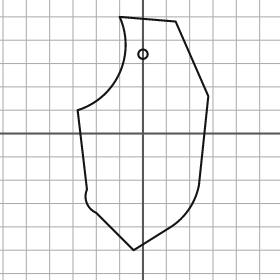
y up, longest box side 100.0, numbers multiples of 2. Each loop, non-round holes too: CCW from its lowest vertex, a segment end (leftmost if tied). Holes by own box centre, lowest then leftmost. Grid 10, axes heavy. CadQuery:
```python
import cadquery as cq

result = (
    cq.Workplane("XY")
    .moveTo(-4.0, -50.0)
    .lineTo(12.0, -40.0)
    .threePointArc((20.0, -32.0), (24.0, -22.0))
    .lineTo(28.0, 16.0)
    .lineTo(14.0, 48.0)
    .lineTo(-10.0, 50.0)
    .threePointArc((-10.0, 26.0), (-28.0, 10.0))
    .lineTo(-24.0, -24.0)
    .threePointArc((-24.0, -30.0), (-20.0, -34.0))
    .close()
    .moveTo(0.0, 34.0)
    .circle(2.0)
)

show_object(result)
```